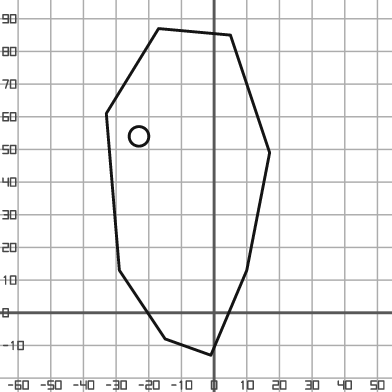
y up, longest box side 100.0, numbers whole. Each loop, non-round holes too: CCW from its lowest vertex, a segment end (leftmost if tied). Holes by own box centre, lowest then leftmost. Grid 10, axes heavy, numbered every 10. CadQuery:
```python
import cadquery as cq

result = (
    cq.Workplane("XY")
    .moveTo(-1.0, -13.0)
    .lineTo(10.0, 13.0)
    .lineTo(17.0, 49.0)
    .lineTo(5.0, 85.0)
    .lineTo(-17.0, 87.0)
    .lineTo(-33.0, 61.0)
    .lineTo(-29.0, 13.0)
    .lineTo(-15.0, -8.0)
    .close()
    .moveTo(-23.0, 54.0)
    .circle(3.0)
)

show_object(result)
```